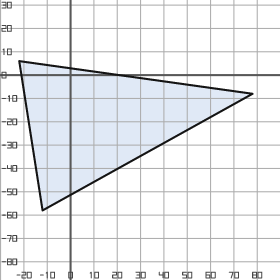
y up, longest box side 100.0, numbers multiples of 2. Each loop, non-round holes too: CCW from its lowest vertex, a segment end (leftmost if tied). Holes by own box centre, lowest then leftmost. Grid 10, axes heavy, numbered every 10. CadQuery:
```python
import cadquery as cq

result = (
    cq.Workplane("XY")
    .moveTo(-12.0, -58.0)
    .lineTo(78.0, -8.0)
    .lineTo(-22.0, 6.0)
    .close()
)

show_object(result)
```